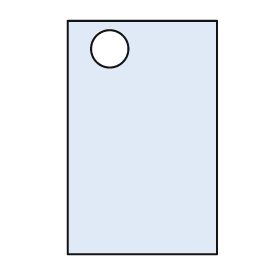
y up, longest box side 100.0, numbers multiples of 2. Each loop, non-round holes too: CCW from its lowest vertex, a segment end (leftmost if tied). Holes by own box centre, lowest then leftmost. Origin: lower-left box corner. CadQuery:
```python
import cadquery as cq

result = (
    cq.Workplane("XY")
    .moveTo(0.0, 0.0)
    .lineTo(64.0, 0.0)
    .lineTo(64.0, 100.0)
    .lineTo(0.0, 100.0)
    .close()
    .moveTo(18.0, 88.0)
    .circle(8.0)
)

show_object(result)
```